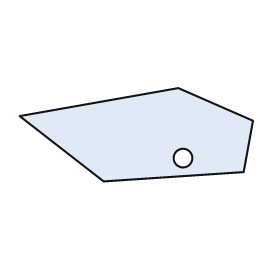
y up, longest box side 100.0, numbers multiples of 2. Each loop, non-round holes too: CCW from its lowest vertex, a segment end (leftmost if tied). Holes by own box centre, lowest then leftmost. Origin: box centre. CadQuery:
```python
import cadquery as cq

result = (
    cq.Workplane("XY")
    .moveTo(-14.0, -20.0)
    .lineTo(46.0, -16.0)
    .lineTo(50.0, 6.0)
    .lineTo(18.0, 20.0)
    .lineTo(-50.0, 8.0)
    .close()
    .moveTo(20.0, -10.0)
    .circle(4.0)
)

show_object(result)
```